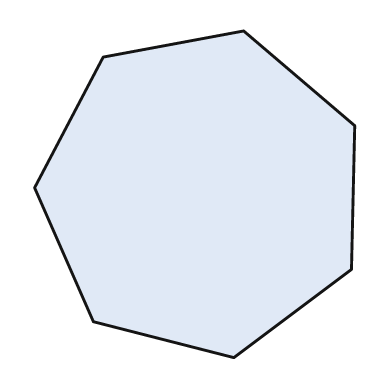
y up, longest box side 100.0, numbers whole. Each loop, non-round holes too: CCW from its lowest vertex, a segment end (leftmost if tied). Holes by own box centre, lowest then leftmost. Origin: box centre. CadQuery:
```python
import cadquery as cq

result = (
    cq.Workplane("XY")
    .moveTo(12.0, -50.0)
    .lineTo(48.0, -23.0)
    .lineTo(49.0, 21.0)
    .lineTo(15.0, 50.0)
    .lineTo(-28.0, 42.0)
    .lineTo(-49.0, 2.0)
    .lineTo(-31.0, -39.0)
    .close()
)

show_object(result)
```